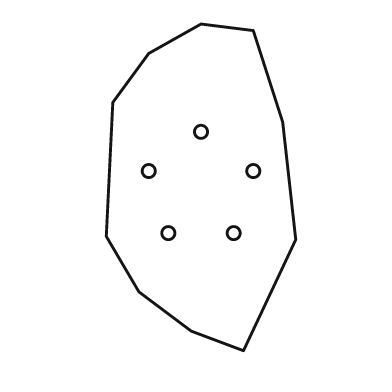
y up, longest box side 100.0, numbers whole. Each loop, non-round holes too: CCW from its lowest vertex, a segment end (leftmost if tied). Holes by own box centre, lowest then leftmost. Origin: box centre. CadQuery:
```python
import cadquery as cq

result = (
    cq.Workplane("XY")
    .moveTo(13.0, -50.0)
    .lineTo(29.0, -16.0)
    .lineTo(25.0, 20.0)
    .lineTo(16.0, 48.0)
    .lineTo(0.0, 50.0)
    .lineTo(-16.0, 41.0)
    .lineTo(-27.0, 26.0)
    .lineTo(-29.0, -15.0)
    .lineTo(-19.0, -32.0)
    .lineTo(-3.0, -44.0)
    .close()
    .moveTo(-10.0, -14.0)
    .circle(2.0)
    .moveTo(10.0, -14.0)
    .circle(2.0)
    .moveTo(-16.0, 5.0)
    .circle(2.0)
    .moveTo(16.0, 5.0)
    .circle(2.0)
    .moveTo(0.0, 17.0)
    .circle(2.0)
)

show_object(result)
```